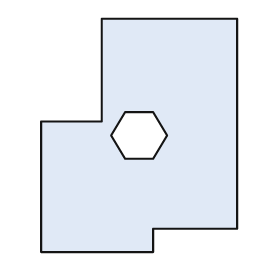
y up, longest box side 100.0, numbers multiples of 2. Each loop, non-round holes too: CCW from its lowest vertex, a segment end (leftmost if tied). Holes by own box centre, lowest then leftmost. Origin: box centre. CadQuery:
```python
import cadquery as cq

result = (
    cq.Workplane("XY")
    .moveTo(-42.0, -50.0)
    .lineTo(6.0, -50.0)
    .lineTo(6.0, -40.0)
    .lineTo(42.0, -40.0)
    .lineTo(42.0, 50.0)
    .lineTo(-16.0, 50.0)
    .lineTo(-16.0, 6.0)
    .lineTo(-42.0, 6.0)
    .close()
    .moveTo(-6.0, -10.0)
    .lineTo(6.0, -10.0)
    .lineTo(12.0, 0.0)
    .lineTo(6.0, 10.0)
    .lineTo(-6.0, 10.0)
    .lineTo(-12.0, 0.0)
    .close()
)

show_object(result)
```